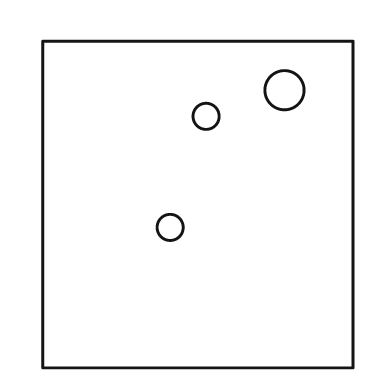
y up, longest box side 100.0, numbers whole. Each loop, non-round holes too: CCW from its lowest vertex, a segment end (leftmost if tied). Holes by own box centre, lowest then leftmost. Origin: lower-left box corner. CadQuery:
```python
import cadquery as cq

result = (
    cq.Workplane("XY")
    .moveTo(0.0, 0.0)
    .lineTo(95.0, 0.0)
    .lineTo(95.0, 100.0)
    .lineTo(0.0, 100.0)
    .close()
    .moveTo(39.0, 43.0)
    .circle(4.0)
    .moveTo(50.0, 77.0)
    .circle(4.0)
    .moveTo(74.0, 85.0)
    .circle(6.0)
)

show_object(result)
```